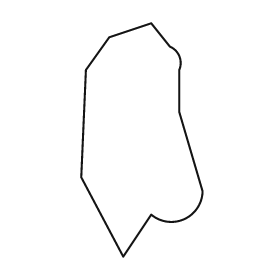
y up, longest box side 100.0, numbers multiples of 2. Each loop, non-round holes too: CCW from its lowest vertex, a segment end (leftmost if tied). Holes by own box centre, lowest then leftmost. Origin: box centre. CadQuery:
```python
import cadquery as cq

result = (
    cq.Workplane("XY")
    .moveTo(-8.0, -50.0)
    .lineTo(4.0, -32.0)
    .threePointArc((18.0, -34.0), (26.0, -22.0))
    .lineTo(16.0, 12.0)
    .lineTo(16.0, 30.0)
    .threePointArc((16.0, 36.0), (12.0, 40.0))
    .lineTo(4.0, 50.0)
    .lineTo(-14.0, 44.0)
    .lineTo(-24.0, 30.0)
    .lineTo(-26.0, -16.0)
    .close()
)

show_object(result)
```